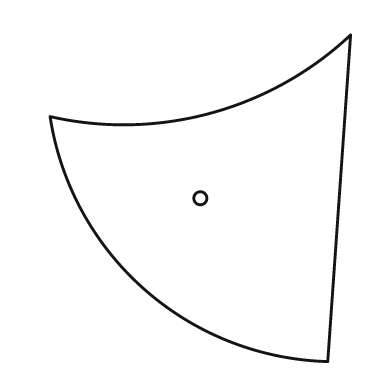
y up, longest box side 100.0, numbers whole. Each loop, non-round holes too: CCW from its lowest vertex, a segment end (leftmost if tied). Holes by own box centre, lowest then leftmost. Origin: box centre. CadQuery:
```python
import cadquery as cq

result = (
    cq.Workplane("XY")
    .moveTo(39.0, -50.0)
    .lineTo(46.0, 50.0)
    .threePointArc((3.0, 26.0), (-46.0, 25.0))
    .threePointArc((-17.0, -28.0), (39.0, -50.0))
    .close()
    .moveTo(0.0, 0.0)
    .circle(2.0)
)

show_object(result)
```